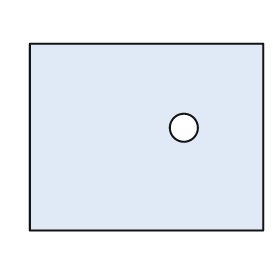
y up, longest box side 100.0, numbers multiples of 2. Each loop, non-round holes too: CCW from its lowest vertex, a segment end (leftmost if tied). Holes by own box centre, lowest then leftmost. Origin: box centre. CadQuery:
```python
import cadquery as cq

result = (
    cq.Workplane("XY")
    .moveTo(-50.0, -40.0)
    .lineTo(50.0, -40.0)
    .lineTo(50.0, 40.0)
    .lineTo(-50.0, 40.0)
    .close()
    .moveTo(16.0, 4.0)
    .circle(6.0)
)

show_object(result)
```